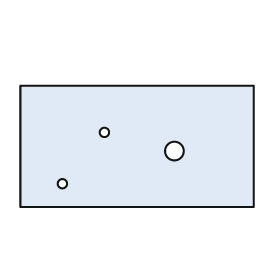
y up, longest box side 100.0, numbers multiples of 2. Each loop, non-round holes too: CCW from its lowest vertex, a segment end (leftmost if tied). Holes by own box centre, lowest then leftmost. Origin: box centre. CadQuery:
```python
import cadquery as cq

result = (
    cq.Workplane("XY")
    .moveTo(-50.0, -26.0)
    .lineTo(50.0, -26.0)
    .lineTo(50.0, 26.0)
    .lineTo(-50.0, 26.0)
    .close()
    .moveTo(-32.0, -16.0)
    .circle(2.0)
    .moveTo(16.0, -2.0)
    .circle(4.0)
    .moveTo(-14.0, 6.0)
    .circle(2.0)
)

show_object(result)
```